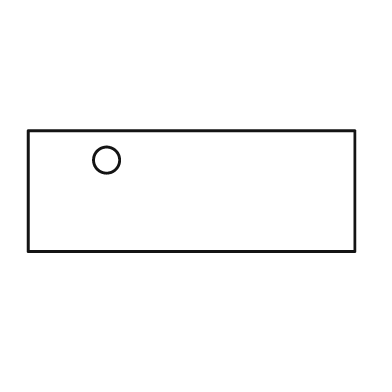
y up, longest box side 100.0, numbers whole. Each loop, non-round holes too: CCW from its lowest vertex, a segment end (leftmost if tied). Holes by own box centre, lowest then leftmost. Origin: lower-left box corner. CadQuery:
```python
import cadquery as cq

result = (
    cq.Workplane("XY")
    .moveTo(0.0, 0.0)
    .lineTo(100.0, 0.0)
    .lineTo(100.0, 37.0)
    .lineTo(0.0, 37.0)
    .close()
    .moveTo(24.0, 28.0)
    .circle(4.0)
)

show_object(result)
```